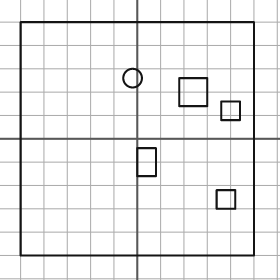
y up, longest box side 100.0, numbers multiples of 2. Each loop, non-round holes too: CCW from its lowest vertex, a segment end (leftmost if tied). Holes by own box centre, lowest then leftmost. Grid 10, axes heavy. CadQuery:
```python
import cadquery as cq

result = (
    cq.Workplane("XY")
    .moveTo(-50.0, -50.0)
    .lineTo(50.0, -50.0)
    .lineTo(50.0, 50.0)
    .lineTo(-50.0, 50.0)
    .close()
    .moveTo(34.0, -30.0)
    .lineTo(42.0, -30.0)
    .lineTo(42.0, -22.0)
    .lineTo(34.0, -22.0)
    .close()
    .moveTo(0.0, -16.0)
    .lineTo(8.0, -16.0)
    .lineTo(8.0, -4.0)
    .lineTo(0.0, -4.0)
    .close()
    .moveTo(36.0, 8.0)
    .lineTo(44.0, 8.0)
    .lineTo(44.0, 16.0)
    .lineTo(36.0, 16.0)
    .close()
    .moveTo(18.0, 14.0)
    .lineTo(30.0, 14.0)
    .lineTo(30.0, 26.0)
    .lineTo(18.0, 26.0)
    .close()
    .moveTo(-2.0, 26.0)
    .circle(4.0)
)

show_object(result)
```